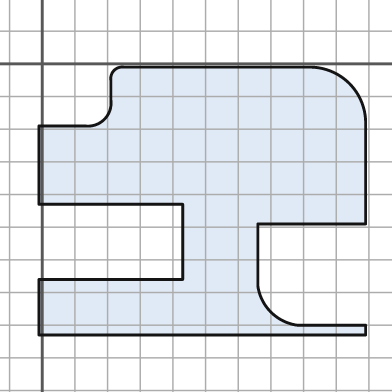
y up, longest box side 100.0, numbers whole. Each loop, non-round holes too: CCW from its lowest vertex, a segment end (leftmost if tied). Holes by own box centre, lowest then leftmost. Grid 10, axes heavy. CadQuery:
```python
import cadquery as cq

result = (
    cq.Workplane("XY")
    .moveTo(-1.0, -83.0)
    .lineTo(99.0, -83.0)
    .lineTo(99.0, -80.0)
    .lineTo(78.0, -80.0)
    .threePointArc((70.0, -76.0), (66.0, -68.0))
    .lineTo(66.0, -49.0)
    .lineTo(99.0, -49.0)
    .lineTo(99.0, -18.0)
    .threePointArc((94.0, -6.0), (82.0, -1.0))
    .lineTo(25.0, -1.0)
    .threePointArc((22.0, -2.0), (21.0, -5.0))
    .lineTo(21.0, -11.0)
    .threePointArc((19.0, -17.0), (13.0, -19.0))
    .lineTo(-1.0, -19.0)
    .lineTo(-1.0, -43.0)
    .lineTo(43.0, -43.0)
    .lineTo(43.0, -66.0)
    .lineTo(-1.0, -66.0)
    .close()
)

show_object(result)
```